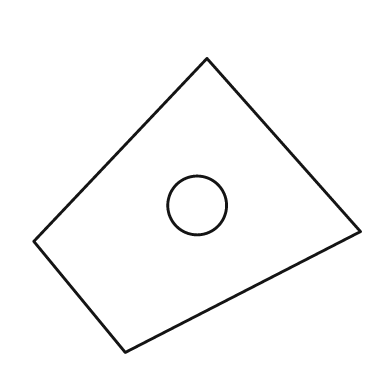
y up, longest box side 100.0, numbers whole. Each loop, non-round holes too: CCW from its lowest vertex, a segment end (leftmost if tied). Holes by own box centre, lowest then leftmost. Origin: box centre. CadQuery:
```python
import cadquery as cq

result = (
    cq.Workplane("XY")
    .moveTo(-22.0, -45.0)
    .lineTo(50.0, -8.0)
    .lineTo(3.0, 45.0)
    .lineTo(-50.0, -11.0)
    .close()
    .moveTo(0.0, 0.0)
    .circle(9.0)
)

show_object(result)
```